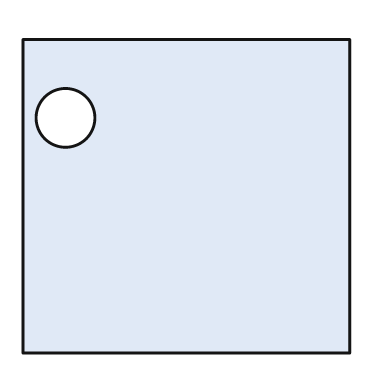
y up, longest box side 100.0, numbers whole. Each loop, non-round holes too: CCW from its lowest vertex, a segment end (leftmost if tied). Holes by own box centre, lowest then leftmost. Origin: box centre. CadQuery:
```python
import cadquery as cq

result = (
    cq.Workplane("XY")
    .moveTo(-50.0, -48.0)
    .lineTo(50.0, -48.0)
    .lineTo(50.0, 48.0)
    .lineTo(-50.0, 48.0)
    .close()
    .moveTo(-37.0, 24.0)
    .circle(9.0)
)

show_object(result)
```